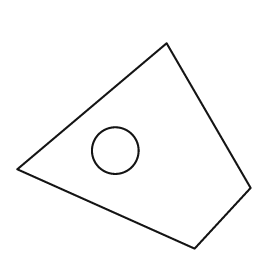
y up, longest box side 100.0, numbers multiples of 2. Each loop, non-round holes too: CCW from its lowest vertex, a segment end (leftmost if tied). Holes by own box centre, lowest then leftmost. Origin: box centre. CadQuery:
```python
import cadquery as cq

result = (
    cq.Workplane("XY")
    .moveTo(26.0, -44.0)
    .lineTo(50.0, -18.0)
    .lineTo(14.0, 44.0)
    .lineTo(-50.0, -10.0)
    .close()
    .moveTo(-8.0, -2.0)
    .circle(10.0)
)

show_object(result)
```